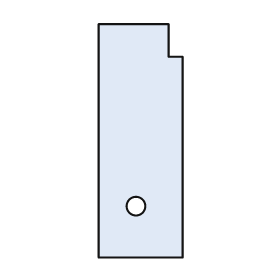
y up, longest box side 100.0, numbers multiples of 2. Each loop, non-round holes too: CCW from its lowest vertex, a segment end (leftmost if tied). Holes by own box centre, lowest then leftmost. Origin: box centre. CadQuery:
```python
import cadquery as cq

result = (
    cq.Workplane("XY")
    .moveTo(-18.0, -50.0)
    .lineTo(18.0, -50.0)
    .lineTo(18.0, 36.0)
    .lineTo(12.0, 36.0)
    .lineTo(12.0, 50.0)
    .lineTo(-18.0, 50.0)
    .close()
    .moveTo(-2.0, -28.0)
    .circle(4.0)
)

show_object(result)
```